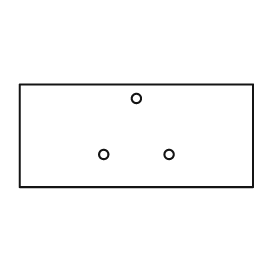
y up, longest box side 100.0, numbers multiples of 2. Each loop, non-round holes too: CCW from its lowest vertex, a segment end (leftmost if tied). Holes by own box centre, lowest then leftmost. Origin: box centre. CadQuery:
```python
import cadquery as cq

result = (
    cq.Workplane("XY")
    .moveTo(-50.0, -22.0)
    .lineTo(50.0, -22.0)
    .lineTo(50.0, 22.0)
    .lineTo(-50.0, 22.0)
    .close()
    .moveTo(-14.0, -8.0)
    .circle(2.0)
    .moveTo(14.0, -8.0)
    .circle(2.0)
    .moveTo(0.0, 16.0)
    .circle(2.0)
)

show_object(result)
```